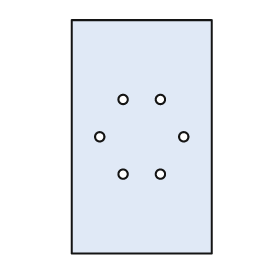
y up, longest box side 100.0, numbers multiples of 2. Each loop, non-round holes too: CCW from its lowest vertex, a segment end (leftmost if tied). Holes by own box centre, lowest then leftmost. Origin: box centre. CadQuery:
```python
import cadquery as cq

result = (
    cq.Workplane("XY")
    .moveTo(-30.0, -50.0)
    .lineTo(30.0, -50.0)
    .lineTo(30.0, 50.0)
    .lineTo(-30.0, 50.0)
    .close()
    .moveTo(-8.0, -16.0)
    .circle(2.0)
    .moveTo(8.0, -16.0)
    .circle(2.0)
    .moveTo(-18.0, 0.0)
    .circle(2.0)
    .moveTo(18.0, 0.0)
    .circle(2.0)
    .moveTo(-8.0, 16.0)
    .circle(2.0)
    .moveTo(8.0, 16.0)
    .circle(2.0)
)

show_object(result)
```